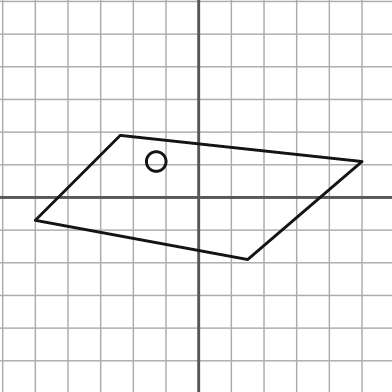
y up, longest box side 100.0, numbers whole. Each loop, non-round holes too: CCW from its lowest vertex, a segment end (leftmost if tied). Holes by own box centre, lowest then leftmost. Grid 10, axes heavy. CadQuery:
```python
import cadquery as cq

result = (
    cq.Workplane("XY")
    .moveTo(15.0, -19.0)
    .lineTo(50.0, 11.0)
    .lineTo(-24.0, 19.0)
    .lineTo(-50.0, -7.0)
    .close()
    .moveTo(-13.0, 11.0)
    .circle(3.0)
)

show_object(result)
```